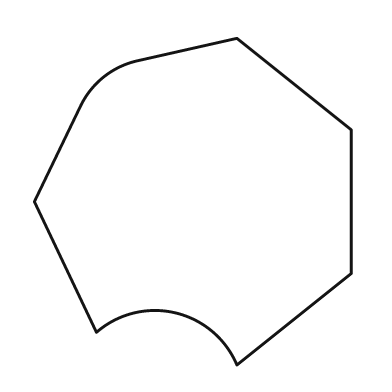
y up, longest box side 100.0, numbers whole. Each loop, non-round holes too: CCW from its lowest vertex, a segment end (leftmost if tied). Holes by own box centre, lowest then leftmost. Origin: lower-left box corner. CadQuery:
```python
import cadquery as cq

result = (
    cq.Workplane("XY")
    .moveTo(62.0, 0.0)
    .lineTo(97.0, 28.0)
    .lineTo(97.0, 72.0)
    .lineTo(62.0, 100.0)
    .lineTo(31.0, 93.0)
    .threePointArc((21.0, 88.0), (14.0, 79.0))
    .lineTo(0.0, 50.0)
    .lineTo(19.0, 10.0)
    .threePointArc((43.0, 16.0), (62.0, 0.0))
    .close()
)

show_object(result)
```